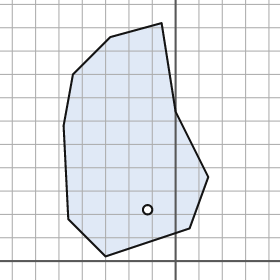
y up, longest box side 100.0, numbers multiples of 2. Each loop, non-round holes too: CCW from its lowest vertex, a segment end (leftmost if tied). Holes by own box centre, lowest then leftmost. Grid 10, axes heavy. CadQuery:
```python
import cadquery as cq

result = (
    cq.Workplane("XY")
    .moveTo(-30.0, 2.0)
    .lineTo(6.0, 14.0)
    .lineTo(14.0, 36.0)
    .lineTo(0.0, 64.0)
    .lineTo(-6.0, 102.0)
    .lineTo(-28.0, 96.0)
    .lineTo(-44.0, 80.0)
    .lineTo(-48.0, 58.0)
    .lineTo(-46.0, 18.0)
    .close()
    .moveTo(-12.0, 22.0)
    .circle(2.0)
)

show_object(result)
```